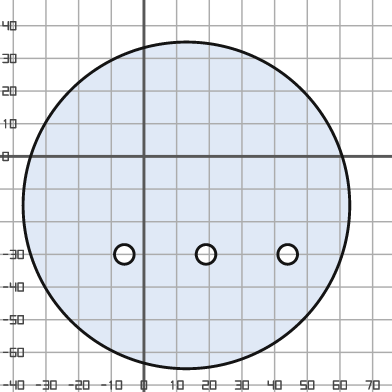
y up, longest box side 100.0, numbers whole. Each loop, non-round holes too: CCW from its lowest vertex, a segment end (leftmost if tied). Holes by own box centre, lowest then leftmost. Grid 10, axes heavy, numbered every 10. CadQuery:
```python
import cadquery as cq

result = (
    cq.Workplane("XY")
    .moveTo(13.0, -15.0)
    .circle(50.0)
    .moveTo(-6.0, -30.0)
    .circle(3.0)
    .moveTo(19.0, -30.0)
    .circle(3.0)
    .moveTo(44.0, -30.0)
    .circle(3.0)
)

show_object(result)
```